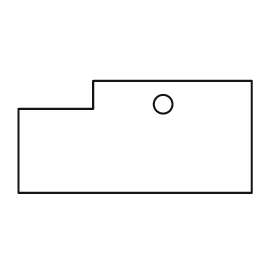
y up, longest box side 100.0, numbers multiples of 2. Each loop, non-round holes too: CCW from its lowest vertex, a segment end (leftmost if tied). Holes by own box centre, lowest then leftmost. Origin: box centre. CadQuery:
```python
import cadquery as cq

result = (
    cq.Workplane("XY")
    .moveTo(-50.0, -24.0)
    .lineTo(50.0, -24.0)
    .lineTo(50.0, 24.0)
    .lineTo(-18.0, 24.0)
    .lineTo(-18.0, 12.0)
    .lineTo(-50.0, 12.0)
    .close()
    .moveTo(12.0, 14.0)
    .circle(4.0)
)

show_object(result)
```